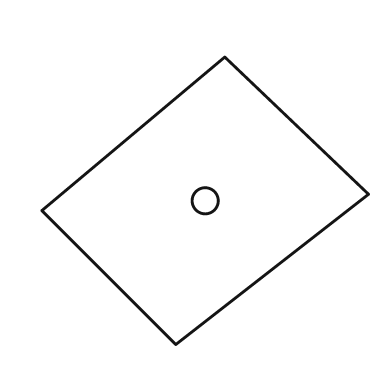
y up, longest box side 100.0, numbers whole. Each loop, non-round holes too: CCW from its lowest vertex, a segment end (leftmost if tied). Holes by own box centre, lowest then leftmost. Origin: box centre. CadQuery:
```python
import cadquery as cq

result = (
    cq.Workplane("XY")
    .moveTo(-9.0, -44.0)
    .lineTo(50.0, 2.0)
    .lineTo(6.0, 44.0)
    .lineTo(-50.0, -3.0)
    .close()
    .moveTo(0.0, 0.0)
    .circle(4.0)
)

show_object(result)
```